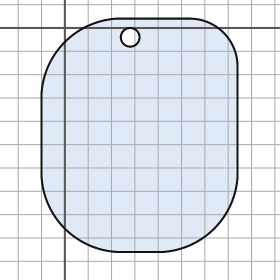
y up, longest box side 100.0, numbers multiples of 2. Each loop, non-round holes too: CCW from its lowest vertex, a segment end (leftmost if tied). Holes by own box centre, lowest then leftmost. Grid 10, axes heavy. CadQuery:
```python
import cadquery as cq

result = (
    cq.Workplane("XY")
    .moveTo(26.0, -96.0)
    .lineTo(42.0, -96.0)
    .threePointArc((64.0, -86.0), (74.0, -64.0))
    .lineTo(74.0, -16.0)
    .threePointArc((68.0, -2.0), (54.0, 4.0))
    .lineTo(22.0, 4.0)
    .threePointArc((0.0, -6.0), (-10.0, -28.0))
    .lineTo(-10.0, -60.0)
    .threePointArc((0.0, -86.0), (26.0, -96.0))
    .close()
    .moveTo(28.0, -4.0)
    .circle(4.0)
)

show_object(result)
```